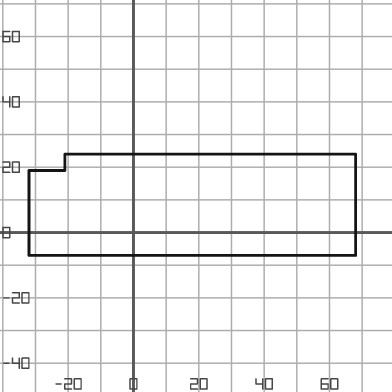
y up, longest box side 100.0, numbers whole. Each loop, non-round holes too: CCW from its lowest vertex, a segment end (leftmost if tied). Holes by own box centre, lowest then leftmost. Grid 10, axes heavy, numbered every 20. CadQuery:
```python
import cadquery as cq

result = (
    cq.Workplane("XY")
    .moveTo(-32.0, -7.0)
    .lineTo(68.0, -7.0)
    .lineTo(68.0, 24.0)
    .lineTo(-21.0, 24.0)
    .lineTo(-21.0, 19.0)
    .lineTo(-32.0, 19.0)
    .close()
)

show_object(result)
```